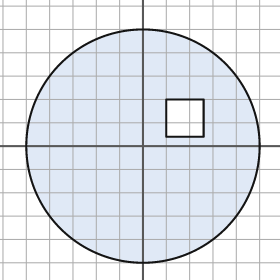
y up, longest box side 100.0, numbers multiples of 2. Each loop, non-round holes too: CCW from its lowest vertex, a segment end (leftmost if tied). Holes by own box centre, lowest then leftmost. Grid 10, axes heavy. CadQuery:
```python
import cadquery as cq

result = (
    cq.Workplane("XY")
    .moveTo(0.0, 0.0)
    .circle(50.0)
    .moveTo(10.0, 4.0)
    .lineTo(26.0, 4.0)
    .lineTo(26.0, 20.0)
    .lineTo(10.0, 20.0)
    .close()
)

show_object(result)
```